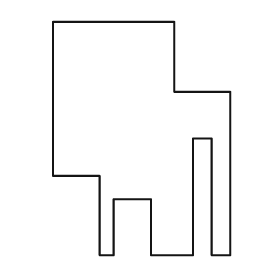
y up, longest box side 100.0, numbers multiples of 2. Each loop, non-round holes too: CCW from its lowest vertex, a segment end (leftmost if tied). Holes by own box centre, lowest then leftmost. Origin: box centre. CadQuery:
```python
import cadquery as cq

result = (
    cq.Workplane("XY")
    .moveTo(-18.0, -50.0)
    .lineTo(-12.0, -50.0)
    .lineTo(-12.0, -26.0)
    .lineTo(4.0, -26.0)
    .lineTo(4.0, -50.0)
    .lineTo(22.0, -50.0)
    .lineTo(22.0, 0.0)
    .lineTo(30.0, 0.0)
    .lineTo(30.0, -50.0)
    .lineTo(38.0, -50.0)
    .lineTo(38.0, 20.0)
    .lineTo(14.0, 20.0)
    .lineTo(14.0, 50.0)
    .lineTo(-38.0, 50.0)
    .lineTo(-38.0, -16.0)
    .lineTo(-18.0, -16.0)
    .close()
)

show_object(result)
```